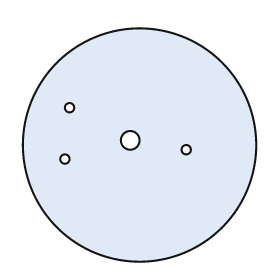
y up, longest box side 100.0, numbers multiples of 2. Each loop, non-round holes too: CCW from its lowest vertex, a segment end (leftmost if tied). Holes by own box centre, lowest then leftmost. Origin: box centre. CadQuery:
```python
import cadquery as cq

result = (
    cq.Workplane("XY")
    .moveTo(0.0, 0.0)
    .circle(50.0)
    .moveTo(-32.0, -6.0)
    .circle(2.0)
    .moveTo(20.0, -2.0)
    .circle(2.0)
    .moveTo(-4.0, 2.0)
    .circle(4.0)
    .moveTo(-30.0, 16.0)
    .circle(2.0)
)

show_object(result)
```